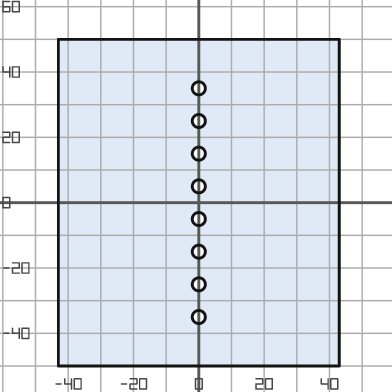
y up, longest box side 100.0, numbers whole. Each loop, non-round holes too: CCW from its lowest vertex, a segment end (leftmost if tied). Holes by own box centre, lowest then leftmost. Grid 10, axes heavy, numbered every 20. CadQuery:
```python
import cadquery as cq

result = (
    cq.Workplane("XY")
    .moveTo(-43.0, -50.0)
    .lineTo(43.0, -50.0)
    .lineTo(43.0, 50.0)
    .lineTo(-43.0, 50.0)
    .close()
    .moveTo(0.0, -35.0)
    .circle(2.0)
    .moveTo(0.0, -25.0)
    .circle(2.0)
    .moveTo(0.0, -15.0)
    .circle(2.0)
    .moveTo(0.0, -5.0)
    .circle(2.0)
    .moveTo(0.0, 5.0)
    .circle(2.0)
    .moveTo(0.0, 15.0)
    .circle(2.0)
    .moveTo(0.0, 25.0)
    .circle(2.0)
    .moveTo(0.0, 35.0)
    .circle(2.0)
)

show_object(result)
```